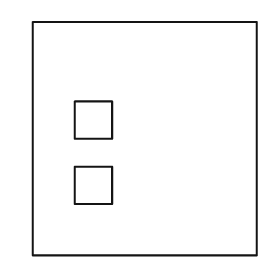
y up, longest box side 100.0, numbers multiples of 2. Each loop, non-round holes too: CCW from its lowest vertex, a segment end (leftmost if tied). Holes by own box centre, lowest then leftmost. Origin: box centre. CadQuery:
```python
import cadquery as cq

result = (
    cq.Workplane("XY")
    .moveTo(-48.0, -50.0)
    .lineTo(48.0, -50.0)
    .lineTo(48.0, 50.0)
    .lineTo(-48.0, 50.0)
    .close()
    .moveTo(-30.0, -28.0)
    .lineTo(-14.0, -28.0)
    .lineTo(-14.0, -12.0)
    .lineTo(-30.0, -12.0)
    .close()
    .moveTo(-30.0, 0.0)
    .lineTo(-14.0, 0.0)
    .lineTo(-14.0, 16.0)
    .lineTo(-30.0, 16.0)
    .close()
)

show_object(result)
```